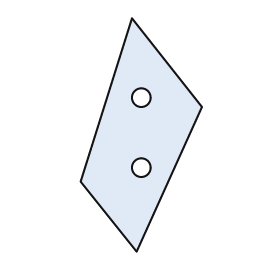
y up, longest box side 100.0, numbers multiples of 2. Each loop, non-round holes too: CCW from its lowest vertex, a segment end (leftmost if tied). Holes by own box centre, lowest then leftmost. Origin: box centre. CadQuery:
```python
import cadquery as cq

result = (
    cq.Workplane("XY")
    .moveTo(-2.0, -50.0)
    .lineTo(26.0, 12.0)
    .lineTo(-4.0, 50.0)
    .lineTo(-26.0, -20.0)
    .close()
    .moveTo(0.0, -14.0)
    .circle(4.0)
    .moveTo(0.0, 16.0)
    .circle(4.0)
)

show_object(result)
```